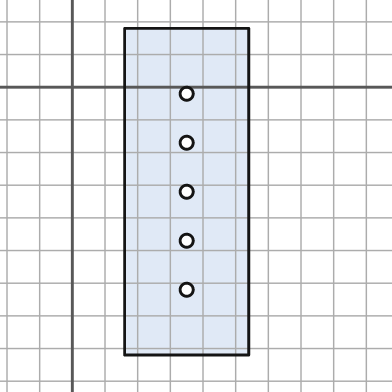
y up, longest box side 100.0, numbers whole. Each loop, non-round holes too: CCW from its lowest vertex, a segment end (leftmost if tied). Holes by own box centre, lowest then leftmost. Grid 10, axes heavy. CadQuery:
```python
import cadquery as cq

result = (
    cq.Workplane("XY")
    .moveTo(16.0, -82.0)
    .lineTo(54.0, -82.0)
    .lineTo(54.0, 18.0)
    .lineTo(16.0, 18.0)
    .close()
    .moveTo(35.0, -62.0)
    .circle(2.0)
    .moveTo(35.0, -47.0)
    .circle(2.0)
    .moveTo(35.0, -32.0)
    .circle(2.0)
    .moveTo(35.0, -17.0)
    .circle(2.0)
    .moveTo(35.0, -2.0)
    .circle(2.0)
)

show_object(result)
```